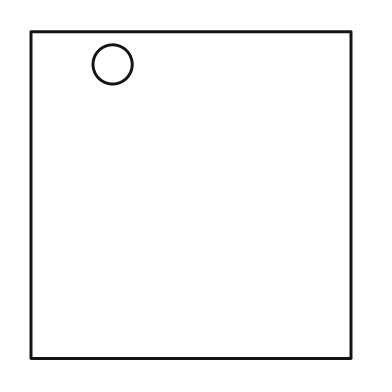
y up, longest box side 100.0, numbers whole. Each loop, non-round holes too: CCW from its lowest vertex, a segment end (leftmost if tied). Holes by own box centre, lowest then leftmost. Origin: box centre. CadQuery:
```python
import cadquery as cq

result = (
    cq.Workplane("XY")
    .moveTo(-49.0, -50.0)
    .lineTo(49.0, -50.0)
    .lineTo(49.0, 50.0)
    .lineTo(-49.0, 50.0)
    .close()
    .moveTo(-24.0, 40.0)
    .circle(6.0)
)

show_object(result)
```